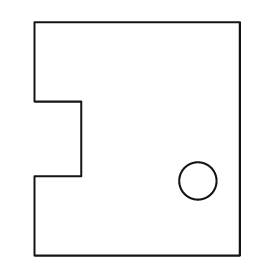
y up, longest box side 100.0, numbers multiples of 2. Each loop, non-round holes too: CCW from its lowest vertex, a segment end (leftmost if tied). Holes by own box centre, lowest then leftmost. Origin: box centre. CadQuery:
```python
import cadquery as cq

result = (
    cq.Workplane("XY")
    .moveTo(-44.0, -50.0)
    .lineTo(44.0, -50.0)
    .lineTo(44.0, 50.0)
    .lineTo(-44.0, 50.0)
    .lineTo(-44.0, 16.0)
    .lineTo(-24.0, 16.0)
    .lineTo(-24.0, -16.0)
    .lineTo(-44.0, -16.0)
    .close()
    .moveTo(26.0, -18.0)
    .circle(8.0)
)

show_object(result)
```